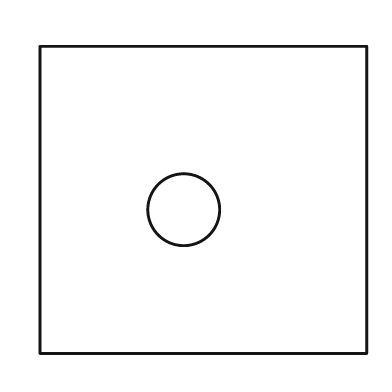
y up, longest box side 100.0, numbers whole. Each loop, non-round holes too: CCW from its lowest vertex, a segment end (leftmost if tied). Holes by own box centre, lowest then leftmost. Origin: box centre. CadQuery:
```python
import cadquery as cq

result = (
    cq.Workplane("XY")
    .moveTo(-50.0, -47.0)
    .lineTo(50.0, -47.0)
    .lineTo(50.0, 47.0)
    .lineTo(-50.0, 47.0)
    .close()
    .moveTo(-6.0, -3.0)
    .circle(11.0)
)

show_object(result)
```